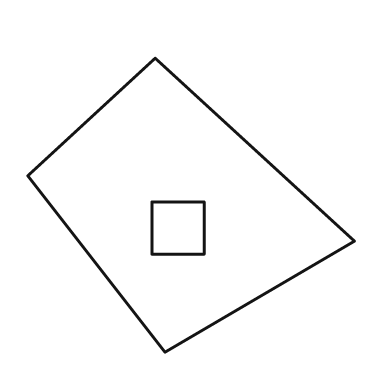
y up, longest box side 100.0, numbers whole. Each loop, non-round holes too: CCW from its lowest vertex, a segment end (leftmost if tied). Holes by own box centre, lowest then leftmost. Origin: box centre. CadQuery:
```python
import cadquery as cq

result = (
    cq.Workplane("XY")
    .moveTo(-8.0, -45.0)
    .lineTo(50.0, -11.0)
    .lineTo(-11.0, 45.0)
    .lineTo(-50.0, 9.0)
    .close()
    .moveTo(-12.0, -15.0)
    .lineTo(4.0, -15.0)
    .lineTo(4.0, 1.0)
    .lineTo(-12.0, 1.0)
    .close()
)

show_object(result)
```